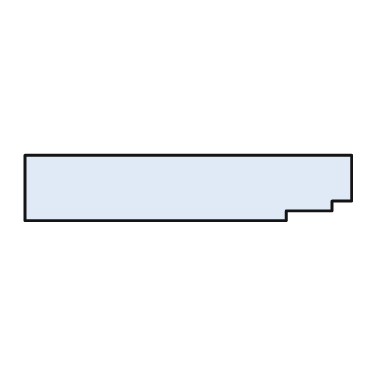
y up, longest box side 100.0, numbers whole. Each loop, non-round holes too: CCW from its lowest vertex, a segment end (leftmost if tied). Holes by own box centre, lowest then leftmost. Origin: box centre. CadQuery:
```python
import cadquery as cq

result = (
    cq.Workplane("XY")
    .moveTo(-50.0, -10.0)
    .lineTo(30.0, -10.0)
    .lineTo(30.0, -7.0)
    .lineTo(44.0, -7.0)
    .lineTo(44.0, -4.0)
    .lineTo(50.0, -4.0)
    .lineTo(50.0, 10.0)
    .lineTo(-50.0, 10.0)
    .close()
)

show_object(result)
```